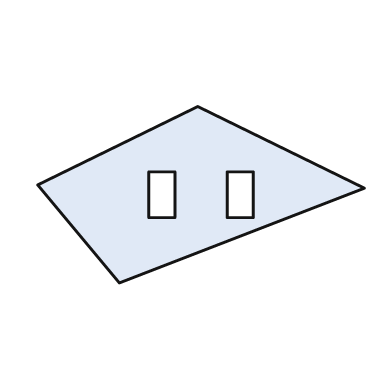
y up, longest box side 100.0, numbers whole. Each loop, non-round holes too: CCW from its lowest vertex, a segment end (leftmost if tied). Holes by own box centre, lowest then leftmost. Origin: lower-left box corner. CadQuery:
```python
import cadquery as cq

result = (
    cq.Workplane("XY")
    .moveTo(25.0, 0.0)
    .lineTo(100.0, 29.0)
    .lineTo(49.0, 54.0)
    .lineTo(0.0, 30.0)
    .close()
    .moveTo(34.0, 20.0)
    .lineTo(42.0, 20.0)
    .lineTo(42.0, 34.0)
    .lineTo(34.0, 34.0)
    .close()
    .moveTo(58.0, 20.0)
    .lineTo(66.0, 20.0)
    .lineTo(66.0, 34.0)
    .lineTo(58.0, 34.0)
    .close()
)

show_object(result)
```